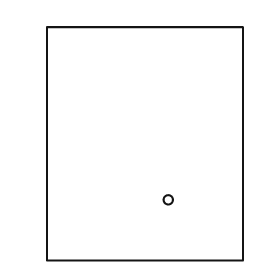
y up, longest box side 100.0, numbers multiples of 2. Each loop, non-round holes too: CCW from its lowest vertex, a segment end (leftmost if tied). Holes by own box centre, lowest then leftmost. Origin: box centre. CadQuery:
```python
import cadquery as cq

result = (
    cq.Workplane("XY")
    .moveTo(-42.0, -50.0)
    .lineTo(42.0, -50.0)
    .lineTo(42.0, 50.0)
    .lineTo(-42.0, 50.0)
    .close()
    .moveTo(10.0, -24.0)
    .circle(2.0)
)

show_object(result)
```